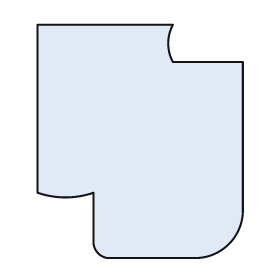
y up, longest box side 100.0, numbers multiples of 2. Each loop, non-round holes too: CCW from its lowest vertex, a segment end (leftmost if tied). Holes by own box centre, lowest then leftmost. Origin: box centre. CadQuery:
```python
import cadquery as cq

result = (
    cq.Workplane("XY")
    .moveTo(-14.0, -50.0)
    .lineTo(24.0, -50.0)
    .threePointArc((38.0, -44.0), (44.0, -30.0))
    .lineTo(44.0, 34.0)
    .lineTo(14.0, 34.0)
    .threePointArc((12.0, 42.0), (14.0, 50.0))
    .lineTo(-44.0, 50.0)
    .lineTo(-44.0, -22.0)
    .threePointArc((-32.0, -24.0), (-20.0, -22.0))
    .lineTo(-20.0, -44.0)
    .threePointArc((-18.0, -48.0), (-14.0, -50.0))
    .close()
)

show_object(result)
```